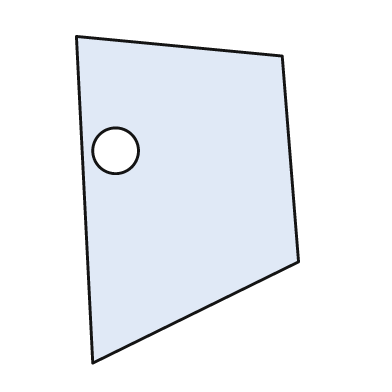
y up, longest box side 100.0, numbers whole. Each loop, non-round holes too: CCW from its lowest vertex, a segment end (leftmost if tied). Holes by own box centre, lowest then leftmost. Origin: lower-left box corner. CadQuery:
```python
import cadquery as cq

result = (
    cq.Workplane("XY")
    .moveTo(5.0, 0.0)
    .lineTo(68.0, 31.0)
    .lineTo(63.0, 94.0)
    .lineTo(0.0, 100.0)
    .close()
    .moveTo(12.0, 65.0)
    .circle(7.0)
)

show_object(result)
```